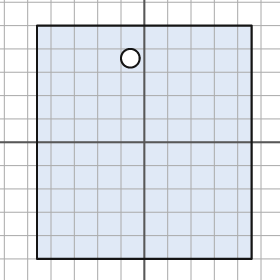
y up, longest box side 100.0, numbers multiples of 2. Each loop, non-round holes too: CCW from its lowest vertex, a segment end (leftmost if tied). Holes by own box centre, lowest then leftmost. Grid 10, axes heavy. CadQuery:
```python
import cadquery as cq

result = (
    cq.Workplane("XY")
    .moveTo(-46.0, -50.0)
    .lineTo(46.0, -50.0)
    .lineTo(46.0, 50.0)
    .lineTo(-46.0, 50.0)
    .close()
    .moveTo(-6.0, 36.0)
    .circle(4.0)
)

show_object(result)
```